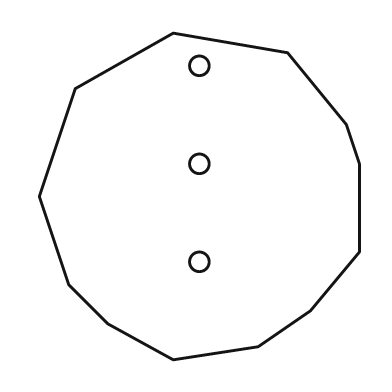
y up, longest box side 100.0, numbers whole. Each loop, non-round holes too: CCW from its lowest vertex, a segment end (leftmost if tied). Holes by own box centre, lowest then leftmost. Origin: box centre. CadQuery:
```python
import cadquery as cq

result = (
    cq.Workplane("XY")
    .moveTo(-8.0, -50.0)
    .lineTo(18.0, -46.0)
    .lineTo(34.0, -35.0)
    .lineTo(49.0, -17.0)
    .lineTo(49.0, 10.0)
    .lineTo(45.0, 22.0)
    .lineTo(27.0, 44.0)
    .lineTo(-8.0, 50.0)
    .lineTo(-38.0, 33.0)
    .lineTo(-49.0, 0.0)
    .lineTo(-40.0, -27.0)
    .lineTo(-28.0, -39.0)
    .close()
    .moveTo(0.0, -20.0)
    .circle(3.0)
    .moveTo(0.0, 10.0)
    .circle(3.0)
    .moveTo(0.0, 40.0)
    .circle(3.0)
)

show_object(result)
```